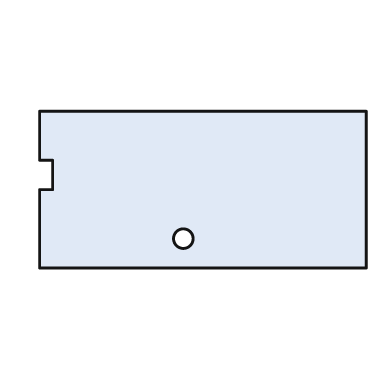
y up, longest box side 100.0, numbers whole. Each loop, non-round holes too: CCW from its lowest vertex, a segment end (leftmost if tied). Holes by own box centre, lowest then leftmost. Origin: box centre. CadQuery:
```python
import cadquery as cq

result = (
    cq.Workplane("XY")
    .moveTo(-50.0, -24.0)
    .lineTo(50.0, -24.0)
    .lineTo(50.0, 24.0)
    .lineTo(-50.0, 24.0)
    .lineTo(-50.0, 9.0)
    .lineTo(-46.0, 9.0)
    .lineTo(-46.0, 0.0)
    .lineTo(-50.0, 0.0)
    .close()
    .moveTo(-6.0, -15.0)
    .circle(3.0)
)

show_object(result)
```